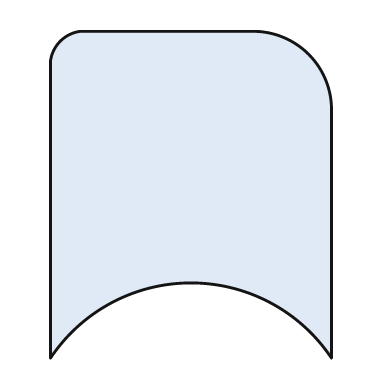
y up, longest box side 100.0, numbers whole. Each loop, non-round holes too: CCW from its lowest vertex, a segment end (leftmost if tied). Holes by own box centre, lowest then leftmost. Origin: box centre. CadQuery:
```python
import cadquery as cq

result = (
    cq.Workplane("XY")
    .moveTo(-43.0, -50.0)
    .threePointArc((0.0, -27.0), (43.0, -50.0))
    .lineTo(43.0, 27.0)
    .threePointArc((36.0, 43.0), (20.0, 50.0))
    .lineTo(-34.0, 50.0)
    .threePointArc((-40.0, 47.0), (-43.0, 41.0))
    .close()
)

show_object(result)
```